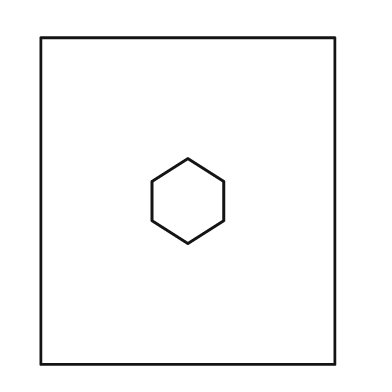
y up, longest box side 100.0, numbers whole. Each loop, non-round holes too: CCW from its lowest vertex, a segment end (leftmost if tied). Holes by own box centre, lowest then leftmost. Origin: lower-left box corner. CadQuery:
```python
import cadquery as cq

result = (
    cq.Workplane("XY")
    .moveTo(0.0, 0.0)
    .lineTo(90.0, 0.0)
    .lineTo(90.0, 100.0)
    .lineTo(0.0, 100.0)
    .close()
    .moveTo(45.0, 37.0)
    .lineTo(56.0, 44.0)
    .lineTo(56.0, 56.0)
    .lineTo(45.0, 63.0)
    .lineTo(34.0, 56.0)
    .lineTo(34.0, 44.0)
    .close()
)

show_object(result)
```